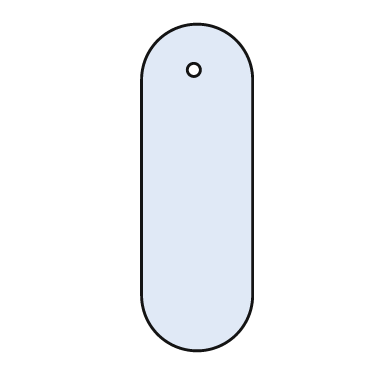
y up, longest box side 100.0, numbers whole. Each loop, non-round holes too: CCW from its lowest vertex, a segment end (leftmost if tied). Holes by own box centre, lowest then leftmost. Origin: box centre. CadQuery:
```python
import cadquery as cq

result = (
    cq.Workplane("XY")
    .moveTo(-17.0, -33.0)
    .threePointArc((0.0, -50.0), (17.0, -33.0))
    .lineTo(17.0, 33.0)
    .threePointArc((0.0, 50.0), (-17.0, 33.0))
    .close()
    .moveTo(-1.0, 36.0)
    .circle(2.0)
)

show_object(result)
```